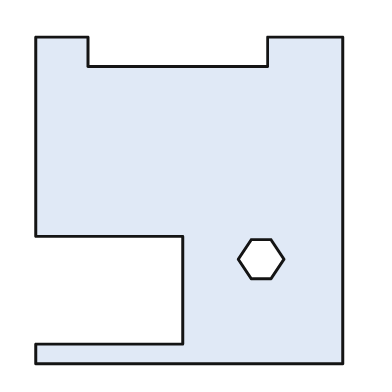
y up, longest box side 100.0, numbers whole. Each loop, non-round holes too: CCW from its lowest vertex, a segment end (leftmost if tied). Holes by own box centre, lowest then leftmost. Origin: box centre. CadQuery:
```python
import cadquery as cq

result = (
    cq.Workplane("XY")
    .moveTo(-47.0, -50.0)
    .lineTo(47.0, -50.0)
    .lineTo(47.0, 50.0)
    .lineTo(24.0, 50.0)
    .lineTo(24.0, 41.0)
    .lineTo(-31.0, 41.0)
    .lineTo(-31.0, 50.0)
    .lineTo(-47.0, 50.0)
    .lineTo(-47.0, -11.0)
    .lineTo(-2.0, -11.0)
    .lineTo(-2.0, -44.0)
    .lineTo(-47.0, -44.0)
    .close()
    .moveTo(19.0, -24.0)
    .lineTo(25.0, -24.0)
    .lineTo(29.0, -18.0)
    .lineTo(25.0, -12.0)
    .lineTo(19.0, -12.0)
    .lineTo(15.0, -18.0)
    .close()
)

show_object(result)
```